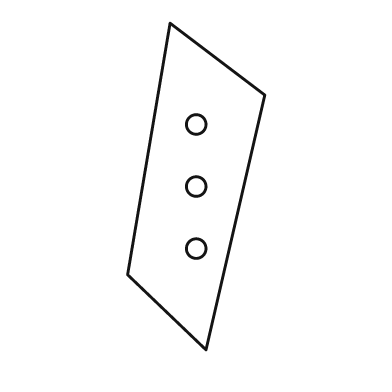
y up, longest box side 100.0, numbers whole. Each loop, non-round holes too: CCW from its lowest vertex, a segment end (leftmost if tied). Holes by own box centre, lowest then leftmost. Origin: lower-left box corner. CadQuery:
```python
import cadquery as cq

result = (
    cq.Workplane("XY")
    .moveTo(24.0, 0.0)
    .lineTo(42.0, 78.0)
    .lineTo(13.0, 100.0)
    .lineTo(0.0, 23.0)
    .close()
    .moveTo(21.0, 31.0)
    .circle(3.0)
    .moveTo(21.0, 50.0)
    .circle(3.0)
    .moveTo(21.0, 69.0)
    .circle(3.0)
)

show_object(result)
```